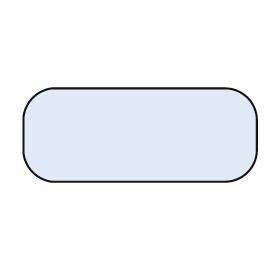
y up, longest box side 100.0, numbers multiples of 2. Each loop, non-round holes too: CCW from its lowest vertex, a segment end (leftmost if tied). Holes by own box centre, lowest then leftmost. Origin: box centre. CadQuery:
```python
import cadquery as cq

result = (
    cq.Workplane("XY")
    .moveTo(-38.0, -20.0)
    .lineTo(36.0, -20.0)
    .threePointArc((46.0, -16.0), (50.0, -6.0))
    .lineTo(50.0, 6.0)
    .threePointArc((46.0, 16.0), (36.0, 20.0))
    .lineTo(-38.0, 20.0)
    .threePointArc((-46.0, 16.0), (-50.0, 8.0))
    .lineTo(-50.0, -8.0)
    .threePointArc((-46.0, -16.0), (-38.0, -20.0))
    .close()
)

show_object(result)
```